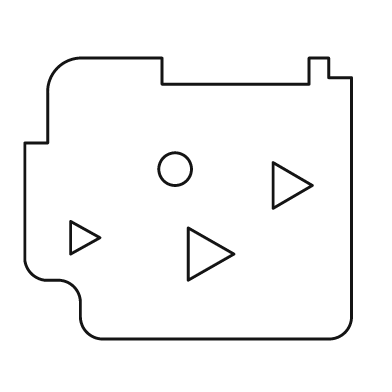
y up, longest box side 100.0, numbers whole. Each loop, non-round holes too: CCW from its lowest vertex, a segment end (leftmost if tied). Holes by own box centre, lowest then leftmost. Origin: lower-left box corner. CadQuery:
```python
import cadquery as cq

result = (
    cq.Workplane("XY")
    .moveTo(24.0, 0.0)
    .lineTo(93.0, 0.0)
    .threePointArc((98.0, 2.0), (100.0, 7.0))
    .lineTo(100.0, 80.0)
    .lineTo(93.0, 80.0)
    .lineTo(93.0, 86.0)
    .lineTo(87.0, 86.0)
    .lineTo(87.0, 78.0)
    .lineTo(42.0, 78.0)
    .lineTo(42.0, 86.0)
    .lineTo(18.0, 86.0)
    .threePointArc((10.0, 83.0), (7.0, 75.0))
    .lineTo(7.0, 60.0)
    .lineTo(0.0, 60.0)
    .lineTo(0.0, 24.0)
    .threePointArc((2.0, 20.0), (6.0, 18.0))
    .lineTo(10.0, 18.0)
    .threePointArc((15.0, 16.0), (17.0, 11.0))
    .lineTo(17.0, 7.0)
    .threePointArc((19.0, 2.0), (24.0, 0.0))
    .close()
    .moveTo(50.0, 18.0)
    .lineTo(64.0, 26.0)
    .lineTo(50.0, 34.0)
    .close()
    .moveTo(14.0, 26.0)
    .lineTo(23.0, 31.0)
    .lineTo(14.0, 36.0)
    .close()
    .moveTo(76.0, 40.0)
    .lineTo(88.0, 47.0)
    .lineTo(76.0, 54.0)
    .close()
    .moveTo(46.0, 52.0)
    .circle(5.0)
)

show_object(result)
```